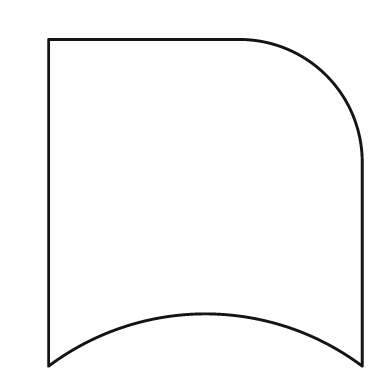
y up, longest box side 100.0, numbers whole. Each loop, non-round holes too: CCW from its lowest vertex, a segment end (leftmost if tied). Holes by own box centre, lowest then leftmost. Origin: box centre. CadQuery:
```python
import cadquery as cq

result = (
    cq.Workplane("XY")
    .moveTo(-48.0, -50.0)
    .threePointArc((0.0, -34.0), (48.0, -50.0))
    .lineTo(48.0, 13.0)
    .threePointArc((37.0, 39.0), (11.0, 50.0))
    .lineTo(-48.0, 50.0)
    .close()
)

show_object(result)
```